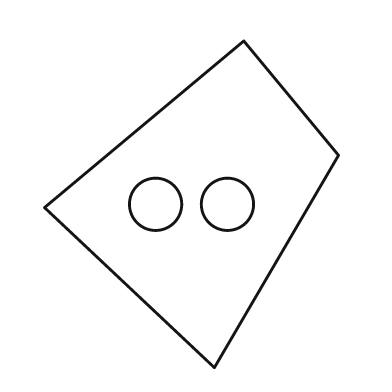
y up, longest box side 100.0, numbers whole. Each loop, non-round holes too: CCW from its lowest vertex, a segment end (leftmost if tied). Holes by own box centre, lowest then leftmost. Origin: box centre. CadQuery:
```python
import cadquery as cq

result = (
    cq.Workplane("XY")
    .moveTo(7.0, -50.0)
    .lineTo(45.0, 15.0)
    .lineTo(16.0, 50.0)
    .lineTo(-45.0, -1.0)
    .close()
    .moveTo(-11.0, 0.0)
    .circle(8.0)
    .moveTo(11.0, 0.0)
    .circle(8.0)
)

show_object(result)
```